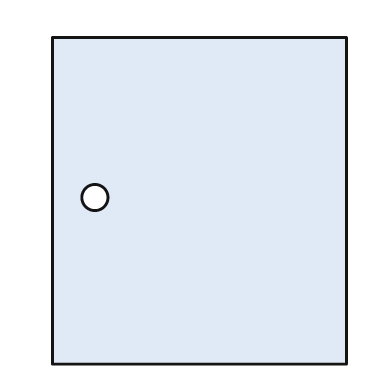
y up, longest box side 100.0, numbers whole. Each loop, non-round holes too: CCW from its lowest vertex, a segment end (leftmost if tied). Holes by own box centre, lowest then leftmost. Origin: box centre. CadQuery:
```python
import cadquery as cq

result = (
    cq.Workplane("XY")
    .moveTo(-45.0, -50.0)
    .lineTo(45.0, -50.0)
    .lineTo(45.0, 50.0)
    .lineTo(-45.0, 50.0)
    .close()
    .moveTo(-32.0, 1.0)
    .circle(4.0)
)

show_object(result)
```